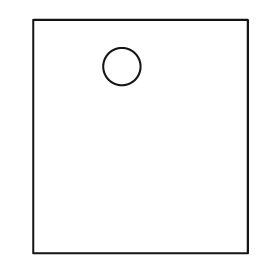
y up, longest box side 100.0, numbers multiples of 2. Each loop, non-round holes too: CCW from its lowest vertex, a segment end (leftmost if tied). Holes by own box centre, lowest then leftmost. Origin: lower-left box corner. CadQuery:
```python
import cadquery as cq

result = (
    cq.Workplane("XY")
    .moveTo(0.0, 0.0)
    .lineTo(92.0, 0.0)
    .lineTo(92.0, 100.0)
    .lineTo(0.0, 100.0)
    .close()
    .moveTo(38.0, 80.0)
    .circle(8.0)
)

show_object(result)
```